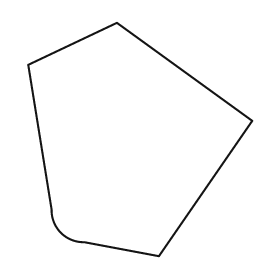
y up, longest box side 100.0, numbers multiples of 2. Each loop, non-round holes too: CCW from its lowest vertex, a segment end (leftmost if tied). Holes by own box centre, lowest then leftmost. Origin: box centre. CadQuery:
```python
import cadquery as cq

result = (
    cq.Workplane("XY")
    .moveTo(8.0, -50.0)
    .lineTo(48.0, 8.0)
    .lineTo(-10.0, 50.0)
    .lineTo(-48.0, 32.0)
    .lineTo(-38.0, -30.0)
    .threePointArc((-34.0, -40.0), (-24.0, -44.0))
    .close()
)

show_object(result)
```